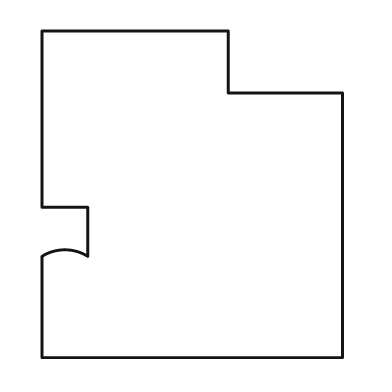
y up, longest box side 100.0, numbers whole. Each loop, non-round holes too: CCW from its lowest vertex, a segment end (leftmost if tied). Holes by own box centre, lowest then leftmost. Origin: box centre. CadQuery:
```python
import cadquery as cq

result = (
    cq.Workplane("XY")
    .moveTo(-46.0, -50.0)
    .lineTo(46.0, -50.0)
    .lineTo(46.0, 31.0)
    .lineTo(11.0, 31.0)
    .lineTo(11.0, 50.0)
    .lineTo(-46.0, 50.0)
    .lineTo(-46.0, -4.0)
    .lineTo(-32.0, -4.0)
    .lineTo(-32.0, -19.0)
    .threePointArc((-39.0, -17.0), (-46.0, -19.0))
    .close()
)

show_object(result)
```